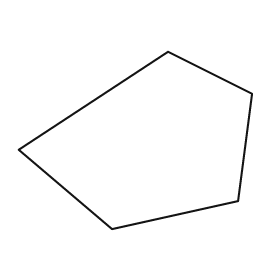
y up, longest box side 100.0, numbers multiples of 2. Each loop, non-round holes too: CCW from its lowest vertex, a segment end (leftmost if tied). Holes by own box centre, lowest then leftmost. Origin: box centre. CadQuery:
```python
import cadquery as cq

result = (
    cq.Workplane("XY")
    .moveTo(-10.0, -38.0)
    .lineTo(44.0, -26.0)
    .lineTo(50.0, 20.0)
    .lineTo(14.0, 38.0)
    .lineTo(-50.0, -4.0)
    .close()
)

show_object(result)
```